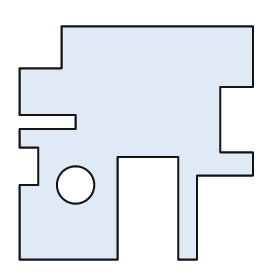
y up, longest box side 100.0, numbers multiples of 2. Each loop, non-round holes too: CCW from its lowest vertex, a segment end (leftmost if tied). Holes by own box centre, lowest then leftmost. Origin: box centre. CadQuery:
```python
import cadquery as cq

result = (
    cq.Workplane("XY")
    .moveTo(-50.0, -50.0)
    .lineTo(-8.0, -50.0)
    .lineTo(-8.0, -6.0)
    .lineTo(18.0, -6.0)
    .lineTo(18.0, -50.0)
    .lineTo(26.0, -50.0)
    .lineTo(26.0, -14.0)
    .lineTo(50.0, -14.0)
    .lineTo(50.0, -4.0)
    .lineTo(36.0, -4.0)
    .lineTo(36.0, 24.0)
    .lineTo(50.0, 24.0)
    .lineTo(50.0, 50.0)
    .lineTo(-32.0, 50.0)
    .lineTo(-32.0, 32.0)
    .lineTo(-50.0, 32.0)
    .lineTo(-50.0, 12.0)
    .lineTo(-26.0, 12.0)
    .lineTo(-26.0, 6.0)
    .lineTo(-50.0, 6.0)
    .lineTo(-50.0, -2.0)
    .lineTo(-42.0, -2.0)
    .lineTo(-42.0, -18.0)
    .lineTo(-50.0, -18.0)
    .close()
    .moveTo(-26.0, -18.0)
    .circle(8.0)
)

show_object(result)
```